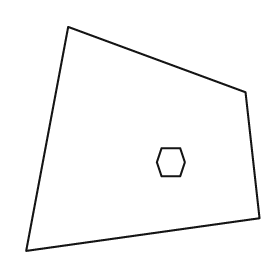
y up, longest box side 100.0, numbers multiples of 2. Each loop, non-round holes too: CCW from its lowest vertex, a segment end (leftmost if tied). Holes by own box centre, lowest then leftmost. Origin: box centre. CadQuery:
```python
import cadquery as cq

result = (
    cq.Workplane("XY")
    .moveTo(-50.0, -48.0)
    .lineTo(50.0, -34.0)
    .lineTo(44.0, 20.0)
    .lineTo(-32.0, 48.0)
    .close()
    .moveTo(8.0, -16.0)
    .lineTo(16.0, -16.0)
    .lineTo(18.0, -10.0)
    .lineTo(16.0, -4.0)
    .lineTo(8.0, -4.0)
    .lineTo(6.0, -10.0)
    .close()
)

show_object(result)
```